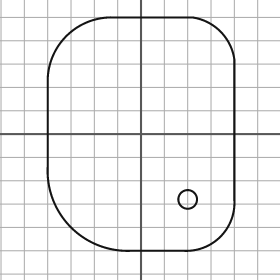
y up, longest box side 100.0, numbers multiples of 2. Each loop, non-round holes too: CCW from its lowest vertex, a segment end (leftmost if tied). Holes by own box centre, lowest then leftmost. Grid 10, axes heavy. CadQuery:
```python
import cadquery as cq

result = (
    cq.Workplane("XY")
    .moveTo(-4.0, -50.0)
    .lineTo(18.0, -50.0)
    .threePointArc((34.0, -44.0), (40.0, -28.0))
    .lineTo(40.0, 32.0)
    .threePointArc((34.0, 44.0), (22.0, 50.0))
    .lineTo(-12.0, 50.0)
    .threePointArc((-32.0, 42.0), (-40.0, 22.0))
    .lineTo(-40.0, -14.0)
    .threePointArc((-30.0, -40.0), (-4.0, -50.0))
    .close()
    .moveTo(20.0, -28.0)
    .circle(4.0)
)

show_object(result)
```